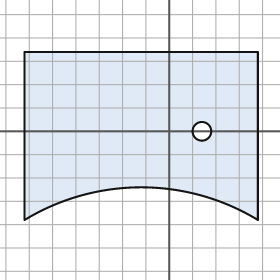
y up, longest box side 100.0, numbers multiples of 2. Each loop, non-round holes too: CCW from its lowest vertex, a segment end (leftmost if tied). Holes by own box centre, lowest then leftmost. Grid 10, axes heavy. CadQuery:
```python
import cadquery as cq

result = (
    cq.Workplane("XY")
    .moveTo(-62.0, -38.0)
    .threePointArc((-12.0, -24.0), (38.0, -38.0))
    .lineTo(38.0, 34.0)
    .lineTo(-62.0, 34.0)
    .close()
    .moveTo(14.0, 0.0)
    .circle(4.0)
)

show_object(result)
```